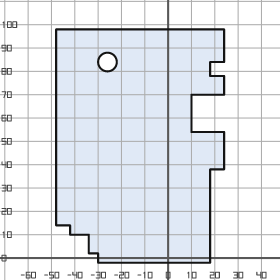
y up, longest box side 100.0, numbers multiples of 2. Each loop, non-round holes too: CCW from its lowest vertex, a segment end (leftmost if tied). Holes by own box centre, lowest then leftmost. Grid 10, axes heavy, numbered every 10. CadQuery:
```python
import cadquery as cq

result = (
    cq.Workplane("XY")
    .moveTo(-30.0, -2.0)
    .lineTo(18.0, -2.0)
    .lineTo(18.0, 38.0)
    .lineTo(24.0, 38.0)
    .lineTo(24.0, 54.0)
    .lineTo(10.0, 54.0)
    .lineTo(10.0, 70.0)
    .lineTo(24.0, 70.0)
    .lineTo(24.0, 78.0)
    .lineTo(18.0, 78.0)
    .lineTo(18.0, 84.0)
    .lineTo(24.0, 84.0)
    .lineTo(24.0, 98.0)
    .lineTo(-48.0, 98.0)
    .lineTo(-48.0, 14.0)
    .lineTo(-42.0, 14.0)
    .lineTo(-42.0, 10.0)
    .lineTo(-34.0, 10.0)
    .lineTo(-34.0, 2.0)
    .lineTo(-30.0, 2.0)
    .close()
    .moveTo(-26.0, 84.0)
    .circle(4.0)
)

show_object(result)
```